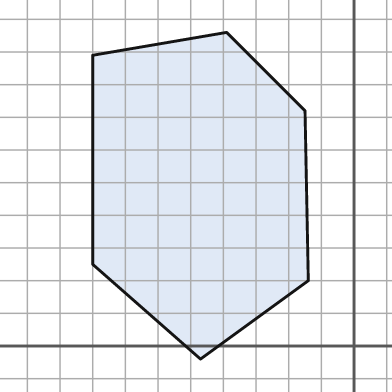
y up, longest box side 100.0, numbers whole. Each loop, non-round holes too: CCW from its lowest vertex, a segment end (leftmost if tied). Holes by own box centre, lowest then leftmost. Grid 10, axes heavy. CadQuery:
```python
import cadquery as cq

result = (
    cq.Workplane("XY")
    .moveTo(-47.0, -4.0)
    .lineTo(-14.0, 20.0)
    .lineTo(-15.0, 72.0)
    .lineTo(-39.0, 96.0)
    .lineTo(-80.0, 89.0)
    .lineTo(-80.0, 25.0)
    .close()
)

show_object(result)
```